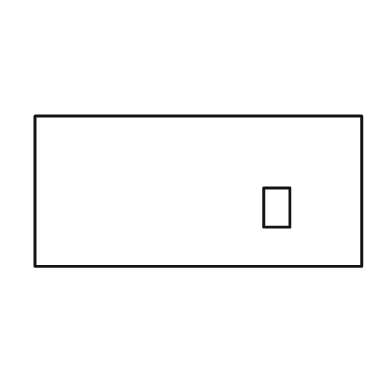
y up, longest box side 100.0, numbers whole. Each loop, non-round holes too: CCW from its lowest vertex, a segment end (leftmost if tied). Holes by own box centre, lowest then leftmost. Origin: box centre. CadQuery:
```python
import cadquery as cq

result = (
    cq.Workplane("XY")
    .moveTo(-50.0, -23.0)
    .lineTo(50.0, -23.0)
    .lineTo(50.0, 23.0)
    .lineTo(-50.0, 23.0)
    .close()
    .moveTo(20.0, -11.0)
    .lineTo(28.0, -11.0)
    .lineTo(28.0, 1.0)
    .lineTo(20.0, 1.0)
    .close()
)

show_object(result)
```